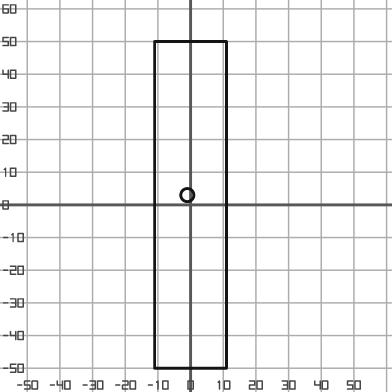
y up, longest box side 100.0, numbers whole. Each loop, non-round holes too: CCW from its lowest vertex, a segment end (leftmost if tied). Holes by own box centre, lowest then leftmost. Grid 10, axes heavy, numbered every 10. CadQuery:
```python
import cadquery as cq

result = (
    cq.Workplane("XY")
    .moveTo(-11.0, -50.0)
    .lineTo(11.0, -50.0)
    .lineTo(11.0, 50.0)
    .lineTo(-11.0, 50.0)
    .close()
    .moveTo(-1.0, 3.0)
    .circle(2.0)
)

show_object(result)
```